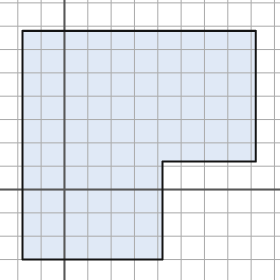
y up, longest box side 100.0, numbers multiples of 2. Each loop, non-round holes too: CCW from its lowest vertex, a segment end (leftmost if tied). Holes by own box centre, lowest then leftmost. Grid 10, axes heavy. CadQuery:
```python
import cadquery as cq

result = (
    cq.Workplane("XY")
    .moveTo(-18.0, -30.0)
    .lineTo(42.0, -30.0)
    .lineTo(42.0, 12.0)
    .lineTo(82.0, 12.0)
    .lineTo(82.0, 68.0)
    .lineTo(-18.0, 68.0)
    .close()
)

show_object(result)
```